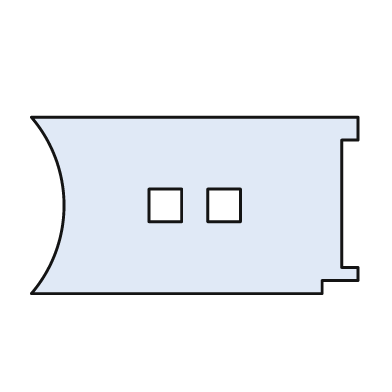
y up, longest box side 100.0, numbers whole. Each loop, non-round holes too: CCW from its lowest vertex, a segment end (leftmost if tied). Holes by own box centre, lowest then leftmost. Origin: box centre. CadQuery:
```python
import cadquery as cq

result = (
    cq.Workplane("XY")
    .moveTo(-50.0, -27.0)
    .lineTo(39.0, -27.0)
    .lineTo(39.0, -23.0)
    .lineTo(50.0, -23.0)
    .lineTo(50.0, -19.0)
    .lineTo(45.0, -19.0)
    .lineTo(45.0, 20.0)
    .lineTo(50.0, 20.0)
    .lineTo(50.0, 27.0)
    .lineTo(-50.0, 27.0)
    .threePointArc((-40.0, 0.0), (-50.0, -27.0))
    .close()
    .moveTo(-14.0, -5.0)
    .lineTo(-4.0, -5.0)
    .lineTo(-4.0, 5.0)
    .lineTo(-14.0, 5.0)
    .close()
    .moveTo(4.0, -5.0)
    .lineTo(14.0, -5.0)
    .lineTo(14.0, 5.0)
    .lineTo(4.0, 5.0)
    .close()
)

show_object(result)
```